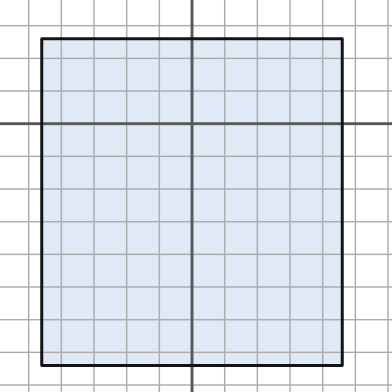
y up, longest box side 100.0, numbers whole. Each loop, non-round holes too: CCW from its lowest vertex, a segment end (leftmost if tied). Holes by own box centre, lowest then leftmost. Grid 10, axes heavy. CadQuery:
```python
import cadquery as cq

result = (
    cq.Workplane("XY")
    .moveTo(-46.0, -74.0)
    .lineTo(46.0, -74.0)
    .lineTo(46.0, 26.0)
    .lineTo(-46.0, 26.0)
    .close()
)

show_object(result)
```